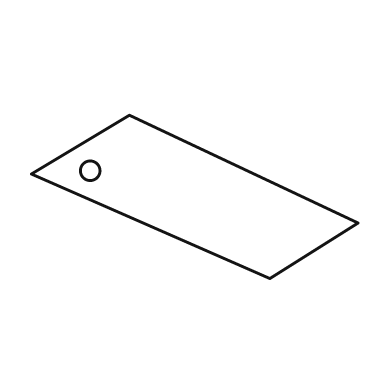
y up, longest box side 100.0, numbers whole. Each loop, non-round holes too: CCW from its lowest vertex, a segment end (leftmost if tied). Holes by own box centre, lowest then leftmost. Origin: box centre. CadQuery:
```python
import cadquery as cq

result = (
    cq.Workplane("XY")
    .moveTo(23.0, -25.0)
    .lineTo(50.0, -8.0)
    .lineTo(-20.0, 25.0)
    .lineTo(-50.0, 7.0)
    .close()
    .moveTo(-32.0, 8.0)
    .circle(3.0)
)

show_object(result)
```